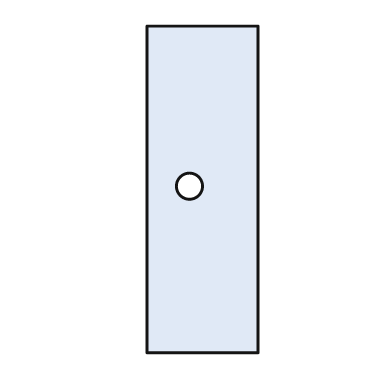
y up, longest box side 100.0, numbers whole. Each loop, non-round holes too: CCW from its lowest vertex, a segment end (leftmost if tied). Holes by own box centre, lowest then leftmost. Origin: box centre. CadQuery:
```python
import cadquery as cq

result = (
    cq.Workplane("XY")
    .moveTo(-17.0, -50.0)
    .lineTo(17.0, -50.0)
    .lineTo(17.0, 50.0)
    .lineTo(-17.0, 50.0)
    .close()
    .moveTo(-4.0, 1.0)
    .circle(4.0)
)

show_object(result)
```